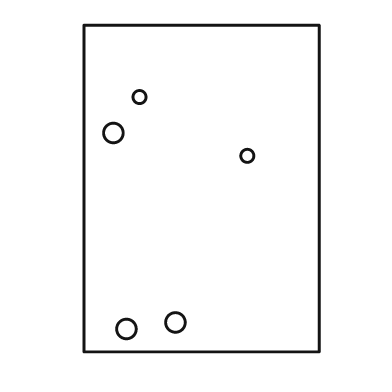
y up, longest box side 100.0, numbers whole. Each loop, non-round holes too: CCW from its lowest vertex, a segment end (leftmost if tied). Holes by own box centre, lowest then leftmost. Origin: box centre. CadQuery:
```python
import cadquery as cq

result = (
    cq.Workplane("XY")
    .moveTo(-36.0, -50.0)
    .lineTo(36.0, -50.0)
    .lineTo(36.0, 50.0)
    .lineTo(-36.0, 50.0)
    .close()
    .moveTo(-23.0, -43.0)
    .circle(3.0)
    .moveTo(-8.0, -41.0)
    .circle(3.0)
    .moveTo(14.0, 10.0)
    .circle(2.0)
    .moveTo(-27.0, 17.0)
    .circle(3.0)
    .moveTo(-19.0, 28.0)
    .circle(2.0)
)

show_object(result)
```